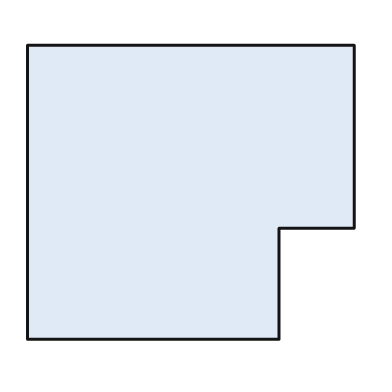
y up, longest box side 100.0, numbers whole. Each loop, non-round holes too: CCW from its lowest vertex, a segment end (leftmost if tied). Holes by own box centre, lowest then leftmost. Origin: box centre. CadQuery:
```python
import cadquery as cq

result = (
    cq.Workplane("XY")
    .moveTo(-50.0, -45.0)
    .lineTo(27.0, -45.0)
    .lineTo(27.0, -11.0)
    .lineTo(50.0, -11.0)
    .lineTo(50.0, 45.0)
    .lineTo(-50.0, 45.0)
    .close()
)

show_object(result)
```